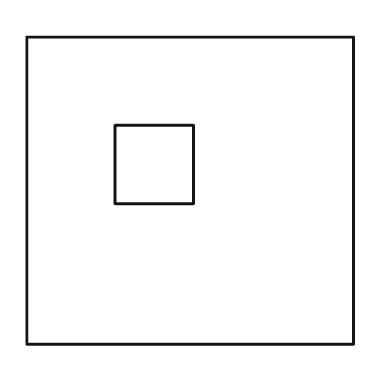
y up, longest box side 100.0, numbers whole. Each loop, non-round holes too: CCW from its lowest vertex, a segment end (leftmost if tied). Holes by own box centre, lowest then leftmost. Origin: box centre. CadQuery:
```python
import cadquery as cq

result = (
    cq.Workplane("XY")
    .moveTo(-50.0, -47.0)
    .lineTo(50.0, -47.0)
    .lineTo(50.0, 47.0)
    .lineTo(-50.0, 47.0)
    .close()
    .moveTo(-23.0, -4.0)
    .lineTo(1.0, -4.0)
    .lineTo(1.0, 20.0)
    .lineTo(-23.0, 20.0)
    .close()
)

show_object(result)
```